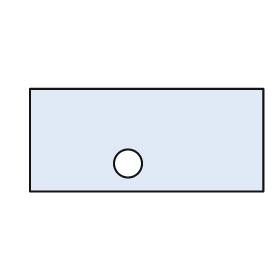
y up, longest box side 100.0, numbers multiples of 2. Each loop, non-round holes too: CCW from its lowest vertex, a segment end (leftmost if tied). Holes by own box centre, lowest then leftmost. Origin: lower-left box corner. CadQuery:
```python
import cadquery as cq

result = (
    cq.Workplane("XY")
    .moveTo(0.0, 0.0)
    .lineTo(100.0, 0.0)
    .lineTo(100.0, 44.0)
    .lineTo(0.0, 44.0)
    .close()
    .moveTo(42.0, 12.0)
    .circle(6.0)
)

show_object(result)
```